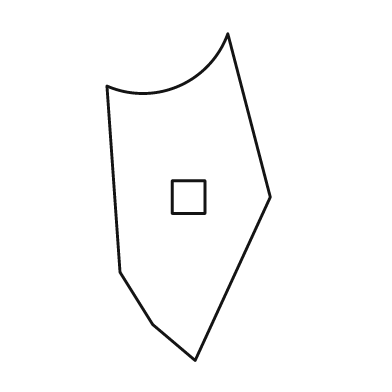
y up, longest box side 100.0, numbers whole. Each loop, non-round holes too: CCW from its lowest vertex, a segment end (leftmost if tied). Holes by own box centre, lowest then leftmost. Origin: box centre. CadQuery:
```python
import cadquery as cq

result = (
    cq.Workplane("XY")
    .moveTo(2.0, -50.0)
    .lineTo(25.0, 0.0)
    .lineTo(12.0, 50.0)
    .threePointArc((-3.0, 34.0), (-25.0, 34.0))
    .lineTo(-21.0, -23.0)
    .lineTo(-11.0, -39.0)
    .close()
    .moveTo(-5.0, -5.0)
    .lineTo(5.0, -5.0)
    .lineTo(5.0, 5.0)
    .lineTo(-5.0, 5.0)
    .close()
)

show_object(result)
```